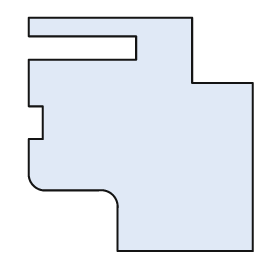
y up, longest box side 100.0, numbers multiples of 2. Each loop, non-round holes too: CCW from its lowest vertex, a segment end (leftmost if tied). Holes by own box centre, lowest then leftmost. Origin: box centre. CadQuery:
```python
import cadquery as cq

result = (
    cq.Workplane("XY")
    .moveTo(-10.0, -50.0)
    .lineTo(48.0, -50.0)
    .lineTo(48.0, 22.0)
    .lineTo(22.0, 22.0)
    .lineTo(22.0, 50.0)
    .lineTo(-48.0, 50.0)
    .lineTo(-48.0, 42.0)
    .lineTo(-2.0, 42.0)
    .lineTo(-2.0, 32.0)
    .lineTo(-48.0, 32.0)
    .lineTo(-48.0, 12.0)
    .lineTo(-42.0, 12.0)
    .lineTo(-42.0, -2.0)
    .lineTo(-48.0, -2.0)
    .lineTo(-48.0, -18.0)
    .threePointArc((-46.0, -22.0), (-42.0, -24.0))
    .lineTo(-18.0, -24.0)
    .threePointArc((-12.0, -26.0), (-10.0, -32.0))
    .close()
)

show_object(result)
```